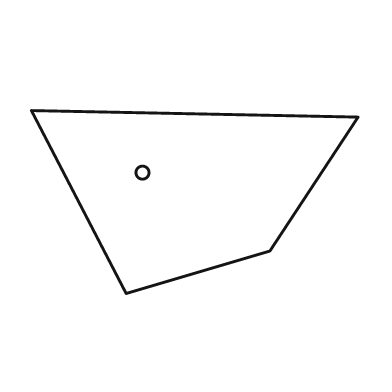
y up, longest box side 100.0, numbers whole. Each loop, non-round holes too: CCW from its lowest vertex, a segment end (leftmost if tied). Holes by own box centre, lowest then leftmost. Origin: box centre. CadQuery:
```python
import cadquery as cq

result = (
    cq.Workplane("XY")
    .moveTo(-21.0, -28.0)
    .lineTo(23.0, -15.0)
    .lineTo(50.0, 26.0)
    .lineTo(-50.0, 28.0)
    .close()
    .moveTo(-16.0, 9.0)
    .circle(2.0)
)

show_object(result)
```